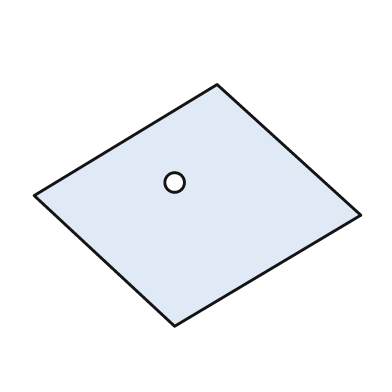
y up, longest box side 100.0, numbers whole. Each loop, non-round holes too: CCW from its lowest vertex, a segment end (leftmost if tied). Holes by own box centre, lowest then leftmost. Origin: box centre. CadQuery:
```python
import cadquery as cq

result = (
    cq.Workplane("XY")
    .moveTo(-7.0, -37.0)
    .lineTo(50.0, -3.0)
    .lineTo(6.0, 37.0)
    .lineTo(-50.0, 3.0)
    .close()
    .moveTo(-7.0, 7.0)
    .circle(3.0)
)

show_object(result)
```